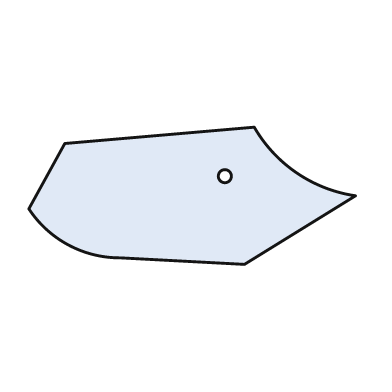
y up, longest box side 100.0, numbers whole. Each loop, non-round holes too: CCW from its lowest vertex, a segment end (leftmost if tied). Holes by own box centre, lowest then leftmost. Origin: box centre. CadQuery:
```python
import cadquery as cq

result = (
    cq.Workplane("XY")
    .moveTo(16.0, -21.0)
    .lineTo(50.0, 0.0)
    .threePointArc((32.0, 7.0), (19.0, 21.0))
    .lineTo(-39.0, 16.0)
    .lineTo(-50.0, -4.0)
    .threePointArc((-38.0, -15.0), (-22.0, -19.0))
    .close()
    .moveTo(10.0, 6.0)
    .circle(2.0)
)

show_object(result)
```